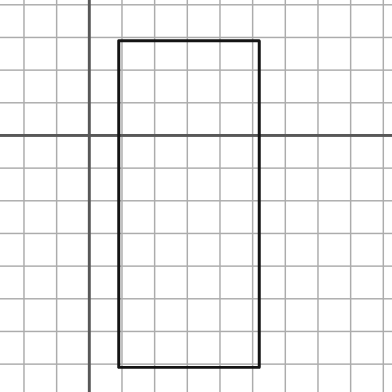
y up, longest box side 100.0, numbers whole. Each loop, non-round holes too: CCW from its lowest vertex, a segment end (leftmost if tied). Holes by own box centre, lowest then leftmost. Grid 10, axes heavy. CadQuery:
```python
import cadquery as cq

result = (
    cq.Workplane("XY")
    .moveTo(9.0, -71.0)
    .lineTo(52.0, -71.0)
    .lineTo(52.0, 29.0)
    .lineTo(9.0, 29.0)
    .close()
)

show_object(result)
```